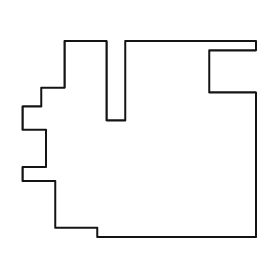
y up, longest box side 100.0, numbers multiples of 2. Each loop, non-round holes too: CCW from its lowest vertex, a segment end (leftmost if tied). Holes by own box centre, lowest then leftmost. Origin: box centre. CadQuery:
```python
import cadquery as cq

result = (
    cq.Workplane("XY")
    .moveTo(-18.0, -42.0)
    .lineTo(50.0, -42.0)
    .lineTo(50.0, 20.0)
    .lineTo(30.0, 20.0)
    .lineTo(30.0, 38.0)
    .lineTo(50.0, 38.0)
    .lineTo(50.0, 42.0)
    .lineTo(-6.0, 42.0)
    .lineTo(-6.0, 8.0)
    .lineTo(-14.0, 8.0)
    .lineTo(-14.0, 42.0)
    .lineTo(-32.0, 42.0)
    .lineTo(-32.0, 22.0)
    .lineTo(-42.0, 22.0)
    .lineTo(-42.0, 14.0)
    .lineTo(-50.0, 14.0)
    .lineTo(-50.0, 4.0)
    .lineTo(-40.0, 4.0)
    .lineTo(-40.0, -12.0)
    .lineTo(-50.0, -12.0)
    .lineTo(-50.0, -18.0)
    .lineTo(-36.0, -18.0)
    .lineTo(-36.0, -38.0)
    .lineTo(-18.0, -38.0)
    .close()
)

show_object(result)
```